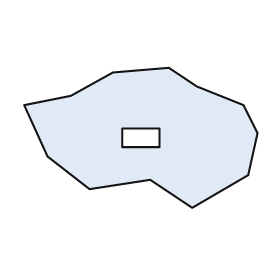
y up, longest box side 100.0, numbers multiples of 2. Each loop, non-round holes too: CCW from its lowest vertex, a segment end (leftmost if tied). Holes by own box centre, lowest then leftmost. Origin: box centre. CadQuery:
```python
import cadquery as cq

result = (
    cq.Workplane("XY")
    .moveTo(22.0, -30.0)
    .lineTo(46.0, -16.0)
    .lineTo(50.0, 2.0)
    .lineTo(44.0, 14.0)
    .lineTo(24.0, 22.0)
    .lineTo(12.0, 30.0)
    .lineTo(-12.0, 28.0)
    .lineTo(-30.0, 18.0)
    .lineTo(-50.0, 14.0)
    .lineTo(-40.0, -8.0)
    .lineTo(-22.0, -22.0)
    .lineTo(4.0, -18.0)
    .close()
    .moveTo(-8.0, -4.0)
    .lineTo(8.0, -4.0)
    .lineTo(8.0, 4.0)
    .lineTo(-8.0, 4.0)
    .close()
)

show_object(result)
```